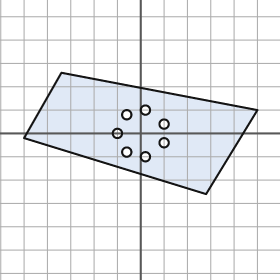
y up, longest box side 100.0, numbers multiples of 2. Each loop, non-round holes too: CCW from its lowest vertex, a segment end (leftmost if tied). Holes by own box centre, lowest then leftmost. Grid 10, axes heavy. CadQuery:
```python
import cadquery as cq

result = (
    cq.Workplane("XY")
    .moveTo(28.0, -26.0)
    .lineTo(50.0, 10.0)
    .lineTo(-34.0, 26.0)
    .lineTo(-50.0, -2.0)
    .close()
    .moveTo(2.0, -10.0)
    .circle(2.0)
    .moveTo(-6.0, -8.0)
    .circle(2.0)
    .moveTo(10.0, -4.0)
    .circle(2.0)
    .moveTo(-10.0, 0.0)
    .circle(2.0)
    .moveTo(10.0, 4.0)
    .circle(2.0)
    .moveTo(-6.0, 8.0)
    .circle(2.0)
    .moveTo(2.0, 10.0)
    .circle(2.0)
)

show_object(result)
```